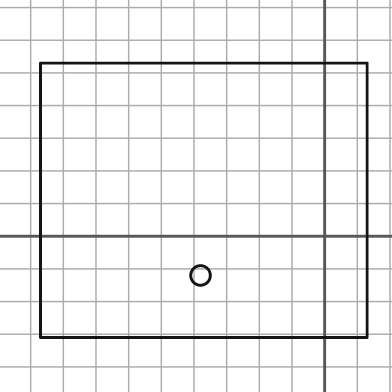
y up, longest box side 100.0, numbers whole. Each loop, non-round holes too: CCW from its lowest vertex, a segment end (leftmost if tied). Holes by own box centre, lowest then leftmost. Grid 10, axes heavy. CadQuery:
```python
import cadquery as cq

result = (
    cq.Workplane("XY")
    .moveTo(-87.0, -31.0)
    .lineTo(13.0, -31.0)
    .lineTo(13.0, 53.0)
    .lineTo(-87.0, 53.0)
    .close()
    .moveTo(-38.0, -12.0)
    .circle(3.0)
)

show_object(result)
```